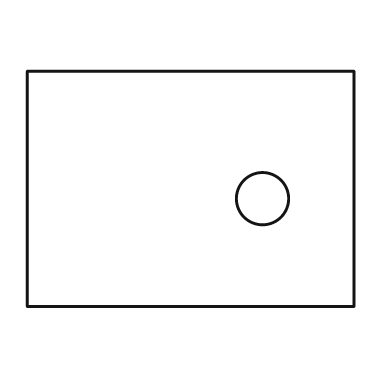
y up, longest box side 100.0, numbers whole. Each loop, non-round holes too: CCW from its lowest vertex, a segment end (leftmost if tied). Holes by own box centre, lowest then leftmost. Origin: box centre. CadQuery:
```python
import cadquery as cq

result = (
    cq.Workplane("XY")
    .moveTo(-50.0, -36.0)
    .lineTo(50.0, -36.0)
    .lineTo(50.0, 36.0)
    .lineTo(-50.0, 36.0)
    .close()
    .moveTo(22.0, -3.0)
    .circle(8.0)
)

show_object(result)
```